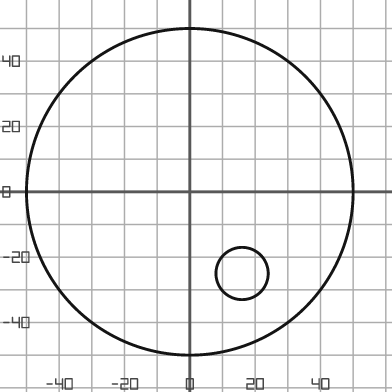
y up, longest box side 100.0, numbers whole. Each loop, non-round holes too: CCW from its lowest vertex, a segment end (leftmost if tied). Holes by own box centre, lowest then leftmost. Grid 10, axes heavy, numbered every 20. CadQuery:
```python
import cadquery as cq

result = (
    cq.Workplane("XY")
    .moveTo(0.0, 0.0)
    .circle(50.0)
    .moveTo(16.0, -25.0)
    .circle(8.0)
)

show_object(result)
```